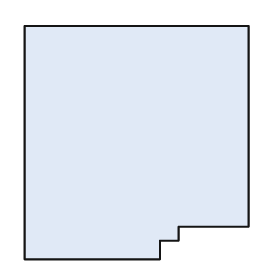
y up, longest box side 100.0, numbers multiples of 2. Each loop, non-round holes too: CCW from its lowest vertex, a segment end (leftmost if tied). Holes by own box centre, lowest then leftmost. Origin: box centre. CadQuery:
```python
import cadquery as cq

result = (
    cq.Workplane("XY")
    .moveTo(-48.0, -50.0)
    .lineTo(10.0, -50.0)
    .lineTo(10.0, -42.0)
    .lineTo(18.0, -42.0)
    .lineTo(18.0, -36.0)
    .lineTo(48.0, -36.0)
    .lineTo(48.0, 50.0)
    .lineTo(-48.0, 50.0)
    .close()
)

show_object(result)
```